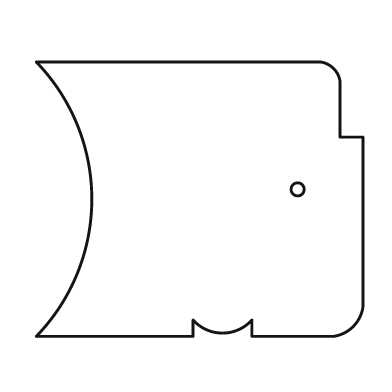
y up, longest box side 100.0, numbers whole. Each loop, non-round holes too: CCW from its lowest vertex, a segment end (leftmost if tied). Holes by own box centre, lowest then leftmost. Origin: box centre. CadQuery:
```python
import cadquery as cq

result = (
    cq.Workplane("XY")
    .moveTo(-50.0, -42.0)
    .lineTo(-2.0, -42.0)
    .lineTo(-2.0, -37.0)
    .threePointArc((7.0, -41.0), (16.0, -37.0))
    .lineTo(16.0, -42.0)
    .lineTo(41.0, -42.0)
    .threePointArc((47.0, -39.0), (50.0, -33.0))
    .lineTo(50.0, 19.0)
    .lineTo(43.0, 19.0)
    .lineTo(43.0, 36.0)
    .threePointArc((41.0, 40.0), (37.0, 42.0))
    .lineTo(-50.0, 42.0)
    .threePointArc((-33.0, 0.0), (-50.0, -42.0))
    .close()
    .moveTo(30.0, 3.0)
    .circle(2.0)
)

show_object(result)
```